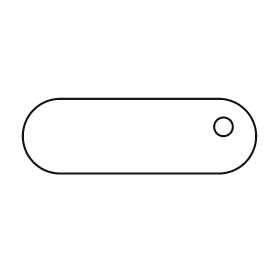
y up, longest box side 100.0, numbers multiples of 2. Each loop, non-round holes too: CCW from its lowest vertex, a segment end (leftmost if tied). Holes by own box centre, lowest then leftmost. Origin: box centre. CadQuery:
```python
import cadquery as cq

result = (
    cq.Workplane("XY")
    .moveTo(-34.0, -16.0)
    .lineTo(34.0, -16.0)
    .threePointArc((50.0, 0.0), (34.0, 16.0))
    .lineTo(-34.0, 16.0)
    .threePointArc((-50.0, 0.0), (-34.0, -16.0))
    .close()
    .moveTo(36.0, 4.0)
    .circle(4.0)
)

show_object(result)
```